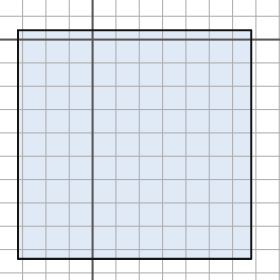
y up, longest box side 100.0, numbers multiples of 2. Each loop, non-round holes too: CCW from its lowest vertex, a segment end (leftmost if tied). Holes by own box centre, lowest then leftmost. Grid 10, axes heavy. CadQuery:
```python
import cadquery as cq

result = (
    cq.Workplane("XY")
    .moveTo(-32.0, -94.0)
    .lineTo(68.0, -94.0)
    .lineTo(68.0, 4.0)
    .lineTo(-32.0, 4.0)
    .close()
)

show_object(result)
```